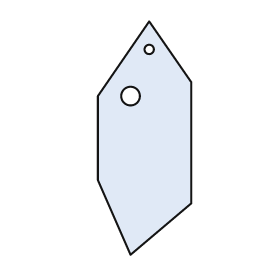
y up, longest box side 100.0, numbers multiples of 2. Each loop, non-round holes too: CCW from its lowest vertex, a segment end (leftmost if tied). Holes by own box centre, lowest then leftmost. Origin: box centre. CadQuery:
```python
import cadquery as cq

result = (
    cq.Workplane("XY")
    .moveTo(-6.0, -50.0)
    .lineTo(20.0, -28.0)
    .lineTo(20.0, 24.0)
    .lineTo(2.0, 50.0)
    .lineTo(-20.0, 18.0)
    .lineTo(-20.0, -18.0)
    .close()
    .moveTo(-6.0, 18.0)
    .circle(4.0)
    .moveTo(2.0, 38.0)
    .circle(2.0)
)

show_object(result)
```